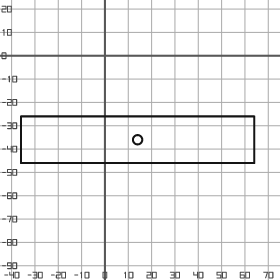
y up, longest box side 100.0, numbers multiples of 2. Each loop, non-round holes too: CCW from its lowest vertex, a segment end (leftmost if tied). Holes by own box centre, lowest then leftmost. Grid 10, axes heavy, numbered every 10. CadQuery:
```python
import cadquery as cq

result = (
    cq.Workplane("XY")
    .moveTo(-36.0, -46.0)
    .lineTo(64.0, -46.0)
    .lineTo(64.0, -26.0)
    .lineTo(-36.0, -26.0)
    .close()
    .moveTo(14.0, -36.0)
    .circle(2.0)
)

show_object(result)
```